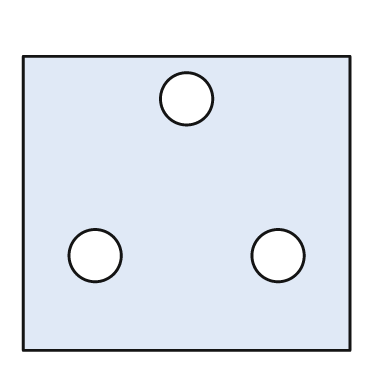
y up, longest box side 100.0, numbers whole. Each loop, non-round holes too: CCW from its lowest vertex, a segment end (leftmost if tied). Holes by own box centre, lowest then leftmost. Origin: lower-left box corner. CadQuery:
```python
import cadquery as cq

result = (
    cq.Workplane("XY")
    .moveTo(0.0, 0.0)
    .lineTo(100.0, 0.0)
    .lineTo(100.0, 90.0)
    .lineTo(0.0, 90.0)
    .close()
    .moveTo(22.0, 29.0)
    .circle(8.0)
    .moveTo(78.0, 29.0)
    .circle(8.0)
    .moveTo(50.0, 77.0)
    .circle(8.0)
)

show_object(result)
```